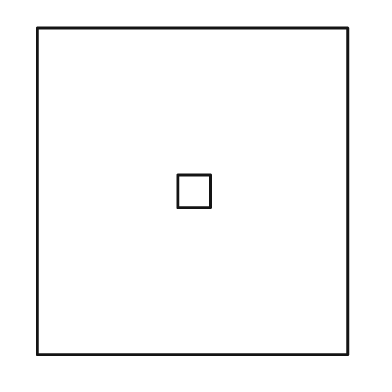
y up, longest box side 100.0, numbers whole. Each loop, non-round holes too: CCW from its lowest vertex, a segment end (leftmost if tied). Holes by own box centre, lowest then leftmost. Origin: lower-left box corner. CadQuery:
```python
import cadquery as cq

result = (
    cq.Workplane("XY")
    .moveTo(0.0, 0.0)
    .lineTo(95.0, 0.0)
    .lineTo(95.0, 100.0)
    .lineTo(0.0, 100.0)
    .close()
    .moveTo(43.0, 45.0)
    .lineTo(53.0, 45.0)
    .lineTo(53.0, 55.0)
    .lineTo(43.0, 55.0)
    .close()
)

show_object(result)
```